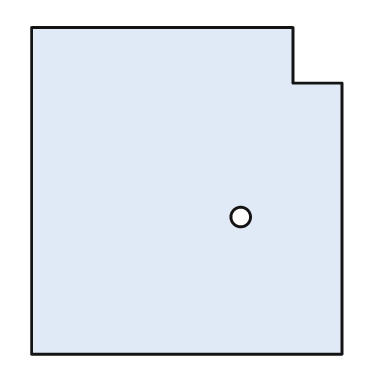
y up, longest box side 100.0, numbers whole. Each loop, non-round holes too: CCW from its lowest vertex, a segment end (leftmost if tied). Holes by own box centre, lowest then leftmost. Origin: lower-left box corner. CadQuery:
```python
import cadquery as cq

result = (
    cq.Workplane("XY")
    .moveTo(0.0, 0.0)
    .lineTo(95.0, 0.0)
    .lineTo(95.0, 83.0)
    .lineTo(80.0, 83.0)
    .lineTo(80.0, 100.0)
    .lineTo(0.0, 100.0)
    .close()
    .moveTo(64.0, 42.0)
    .circle(3.0)
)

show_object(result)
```